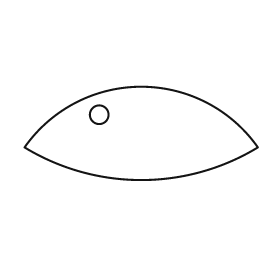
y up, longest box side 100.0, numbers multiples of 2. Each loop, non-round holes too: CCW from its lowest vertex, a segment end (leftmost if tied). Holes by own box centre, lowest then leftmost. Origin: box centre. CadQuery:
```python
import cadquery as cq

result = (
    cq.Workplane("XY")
    .moveTo(-50.0, -6.0)
    .threePointArc((0.0, -20.0), (50.0, -6.0))
    .threePointArc((0.0, 20.0), (-50.0, -6.0))
    .close()
    .moveTo(-18.0, 8.0)
    .circle(4.0)
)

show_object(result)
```